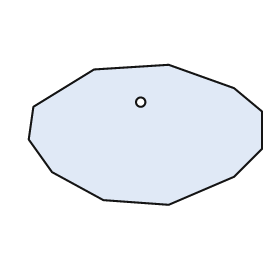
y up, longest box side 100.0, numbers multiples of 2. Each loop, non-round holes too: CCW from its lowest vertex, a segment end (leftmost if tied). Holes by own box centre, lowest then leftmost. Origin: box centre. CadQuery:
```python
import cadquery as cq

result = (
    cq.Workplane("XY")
    .moveTo(10.0, -30.0)
    .lineTo(38.0, -18.0)
    .lineTo(50.0, -6.0)
    .lineTo(50.0, 10.0)
    .lineTo(38.0, 20.0)
    .lineTo(10.0, 30.0)
    .lineTo(-22.0, 28.0)
    .lineTo(-48.0, 12.0)
    .lineTo(-50.0, -2.0)
    .lineTo(-40.0, -16.0)
    .lineTo(-18.0, -28.0)
    .close()
    .moveTo(-2.0, 14.0)
    .circle(2.0)
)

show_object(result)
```